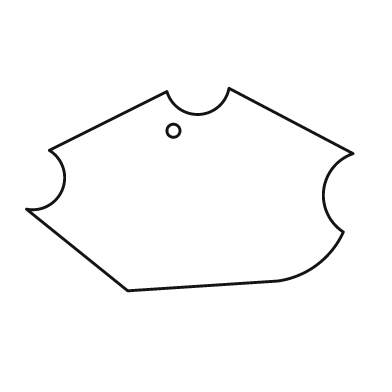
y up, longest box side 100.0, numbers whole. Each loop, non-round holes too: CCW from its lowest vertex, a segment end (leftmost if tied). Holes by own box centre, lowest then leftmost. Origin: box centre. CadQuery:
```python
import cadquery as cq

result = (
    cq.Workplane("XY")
    .moveTo(-19.0, -31.0)
    .lineTo(27.0, -28.0)
    .threePointArc((39.0, -23.0), (47.0, -13.0))
    .threePointArc((41.0, 0.0), (50.0, 11.0))
    .lineTo(12.0, 31.0)
    .threePointArc((3.0, 23.0), (-7.0, 30.0))
    .lineTo(-43.0, 12.0)
    .threePointArc((-39.0, 0.0), (-50.0, -6.0))
    .close()
    .moveTo(-5.0, 18.0)
    .circle(2.0)
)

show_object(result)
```